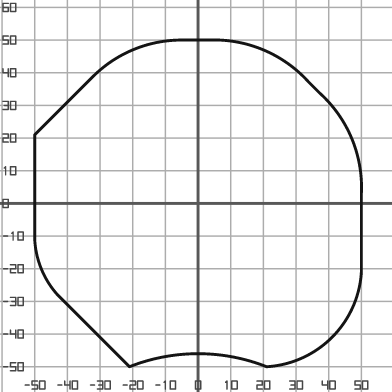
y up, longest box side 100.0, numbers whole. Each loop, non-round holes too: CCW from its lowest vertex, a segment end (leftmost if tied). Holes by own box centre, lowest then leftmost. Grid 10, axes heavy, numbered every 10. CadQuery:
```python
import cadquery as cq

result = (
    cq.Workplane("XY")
    .moveTo(-21.0, -50.0)
    .threePointArc((0.0, -46.0), (21.0, -50.0))
    .threePointArc((41.0, -41.0), (50.0, -21.0))
    .lineTo(50.0, 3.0)
    .threePointArc((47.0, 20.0), (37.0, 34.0))
    .lineTo(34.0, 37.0)
    .threePointArc((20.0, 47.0), (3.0, 50.0))
    .lineTo(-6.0, 50.0)
    .threePointArc((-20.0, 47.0), (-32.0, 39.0))
    .lineTo(-50.0, 21.0)
    .lineTo(-50.0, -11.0)
    .threePointArc((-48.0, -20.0), (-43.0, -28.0))
    .close()
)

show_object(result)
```